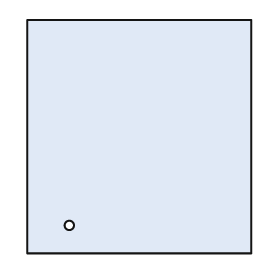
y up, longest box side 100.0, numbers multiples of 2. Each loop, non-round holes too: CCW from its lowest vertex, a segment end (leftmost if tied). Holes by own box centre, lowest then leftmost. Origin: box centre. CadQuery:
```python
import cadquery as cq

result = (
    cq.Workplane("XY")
    .moveTo(-48.0, -50.0)
    .lineTo(48.0, -50.0)
    .lineTo(48.0, 50.0)
    .lineTo(-48.0, 50.0)
    .close()
    .moveTo(-30.0, -38.0)
    .circle(2.0)
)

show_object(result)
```